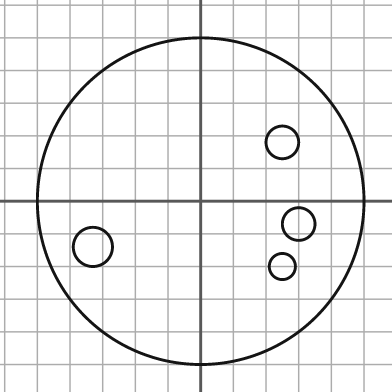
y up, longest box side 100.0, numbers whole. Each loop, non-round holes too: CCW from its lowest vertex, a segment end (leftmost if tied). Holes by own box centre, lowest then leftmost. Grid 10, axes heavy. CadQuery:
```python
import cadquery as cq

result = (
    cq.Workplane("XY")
    .moveTo(0.0, 0.0)
    .circle(50.0)
    .moveTo(25.0, -20.0)
    .circle(4.0)
    .moveTo(-33.0, -14.0)
    .circle(6.0)
    .moveTo(30.0, -7.0)
    .circle(5.0)
    .moveTo(25.0, 18.0)
    .circle(5.0)
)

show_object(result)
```